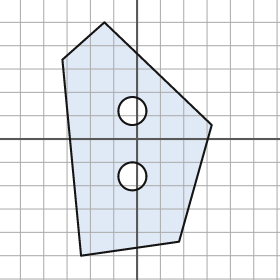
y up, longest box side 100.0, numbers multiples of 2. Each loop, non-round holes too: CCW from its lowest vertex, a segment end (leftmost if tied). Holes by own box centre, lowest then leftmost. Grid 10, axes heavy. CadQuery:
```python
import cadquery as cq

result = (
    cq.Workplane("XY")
    .moveTo(-24.0, -50.0)
    .lineTo(18.0, -44.0)
    .lineTo(32.0, 6.0)
    .lineTo(-14.0, 50.0)
    .lineTo(-32.0, 34.0)
    .close()
    .moveTo(-2.0, -16.0)
    .circle(6.0)
    .moveTo(-2.0, 12.0)
    .circle(6.0)
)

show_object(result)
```